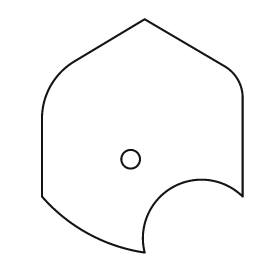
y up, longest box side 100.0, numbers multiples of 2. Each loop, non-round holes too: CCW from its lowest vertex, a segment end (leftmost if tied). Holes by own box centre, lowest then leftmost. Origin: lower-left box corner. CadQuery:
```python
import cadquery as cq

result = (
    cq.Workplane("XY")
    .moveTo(44.0, 0.0)
    .threePointArc((56.0, 28.0), (86.0, 24.0))
    .lineTo(86.0, 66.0)
    .threePointArc((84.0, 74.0), (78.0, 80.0))
    .lineTo(44.0, 100.0)
    .lineTo(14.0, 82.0)
    .threePointArc((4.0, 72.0), (0.0, 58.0))
    .lineTo(0.0, 24.0)
    .threePointArc((20.0, 8.0), (44.0, 0.0))
    .close()
    .moveTo(38.0, 40.0)
    .circle(4.0)
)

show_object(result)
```